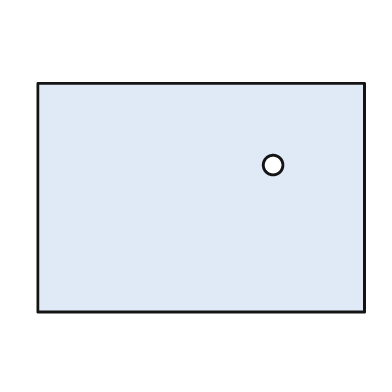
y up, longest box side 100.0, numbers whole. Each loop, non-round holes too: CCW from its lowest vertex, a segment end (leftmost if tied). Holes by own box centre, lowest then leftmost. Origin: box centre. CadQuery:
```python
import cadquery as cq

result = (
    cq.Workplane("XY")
    .moveTo(-50.0, -35.0)
    .lineTo(50.0, -35.0)
    .lineTo(50.0, 35.0)
    .lineTo(-50.0, 35.0)
    .close()
    .moveTo(22.0, 10.0)
    .circle(3.0)
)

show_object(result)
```